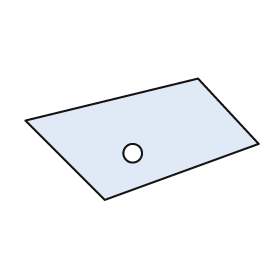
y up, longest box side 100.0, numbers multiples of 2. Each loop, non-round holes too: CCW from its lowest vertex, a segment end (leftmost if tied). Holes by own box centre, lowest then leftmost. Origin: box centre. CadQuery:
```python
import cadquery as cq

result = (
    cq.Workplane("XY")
    .moveTo(-16.0, -26.0)
    .lineTo(50.0, -2.0)
    .lineTo(24.0, 26.0)
    .lineTo(-50.0, 8.0)
    .close()
    .moveTo(-4.0, -6.0)
    .circle(4.0)
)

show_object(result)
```